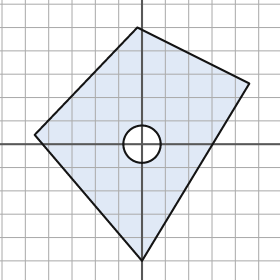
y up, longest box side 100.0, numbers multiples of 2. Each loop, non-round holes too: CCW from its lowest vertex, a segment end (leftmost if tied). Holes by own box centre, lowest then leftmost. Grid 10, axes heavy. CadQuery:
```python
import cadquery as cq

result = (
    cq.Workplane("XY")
    .moveTo(0.0, -50.0)
    .lineTo(46.0, 26.0)
    .lineTo(-2.0, 50.0)
    .lineTo(-46.0, 4.0)
    .close()
    .moveTo(0.0, 0.0)
    .circle(8.0)
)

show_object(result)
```